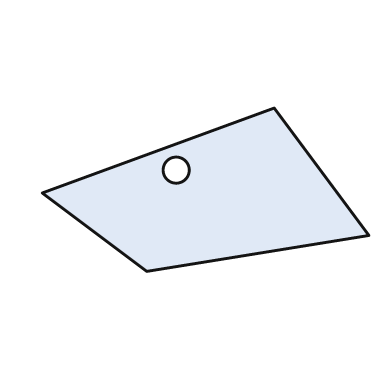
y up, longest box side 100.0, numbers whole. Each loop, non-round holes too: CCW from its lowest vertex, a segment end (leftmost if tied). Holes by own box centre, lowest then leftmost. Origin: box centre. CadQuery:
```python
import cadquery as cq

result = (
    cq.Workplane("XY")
    .moveTo(-18.0, -25.0)
    .lineTo(50.0, -14.0)
    .lineTo(21.0, 25.0)
    .lineTo(-50.0, -1.0)
    .close()
    .moveTo(-9.0, 6.0)
    .circle(4.0)
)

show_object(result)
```